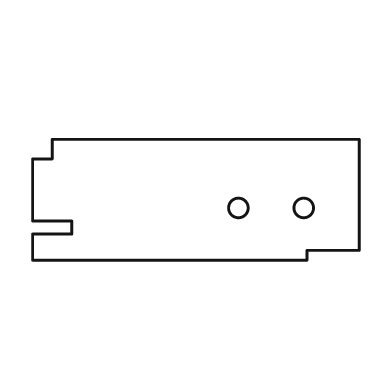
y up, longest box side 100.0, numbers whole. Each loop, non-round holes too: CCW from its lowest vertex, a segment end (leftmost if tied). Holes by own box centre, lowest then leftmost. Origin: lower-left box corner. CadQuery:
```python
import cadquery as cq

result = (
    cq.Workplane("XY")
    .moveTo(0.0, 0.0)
    .lineTo(84.0, 0.0)
    .lineTo(84.0, 3.0)
    .lineTo(100.0, 3.0)
    .lineTo(100.0, 37.0)
    .lineTo(6.0, 37.0)
    .lineTo(6.0, 31.0)
    .lineTo(0.0, 31.0)
    .lineTo(0.0, 12.0)
    .lineTo(12.0, 12.0)
    .lineTo(12.0, 8.0)
    .lineTo(0.0, 8.0)
    .close()
    .moveTo(63.0, 16.0)
    .circle(3.0)
    .moveTo(83.0, 16.0)
    .circle(3.0)
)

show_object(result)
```